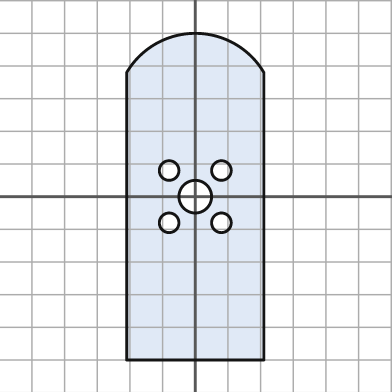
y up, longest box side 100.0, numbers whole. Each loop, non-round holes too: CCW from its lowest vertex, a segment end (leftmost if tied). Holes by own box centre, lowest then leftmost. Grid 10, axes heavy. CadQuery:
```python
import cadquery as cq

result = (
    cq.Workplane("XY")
    .moveTo(-21.0, -50.0)
    .lineTo(21.0, -50.0)
    .lineTo(21.0, 38.0)
    .threePointArc((0.0, 50.0), (-21.0, 38.0))
    .close()
    .moveTo(-8.0, -8.0)
    .circle(3.0)
    .moveTo(8.0, -8.0)
    .circle(3.0)
    .moveTo(0.0, 0.0)
    .circle(5.0)
    .moveTo(-8.0, 8.0)
    .circle(3.0)
    .moveTo(8.0, 8.0)
    .circle(3.0)
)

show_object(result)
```